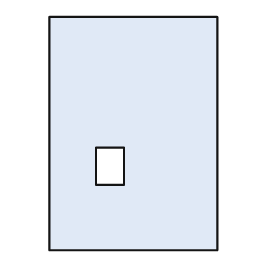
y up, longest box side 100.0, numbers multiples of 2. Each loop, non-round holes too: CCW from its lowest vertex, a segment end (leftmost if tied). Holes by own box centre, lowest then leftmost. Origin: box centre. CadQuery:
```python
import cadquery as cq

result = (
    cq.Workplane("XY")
    .moveTo(-36.0, -50.0)
    .lineTo(36.0, -50.0)
    .lineTo(36.0, 50.0)
    .lineTo(-36.0, 50.0)
    .close()
    .moveTo(-16.0, -22.0)
    .lineTo(-4.0, -22.0)
    .lineTo(-4.0, -6.0)
    .lineTo(-16.0, -6.0)
    .close()
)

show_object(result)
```